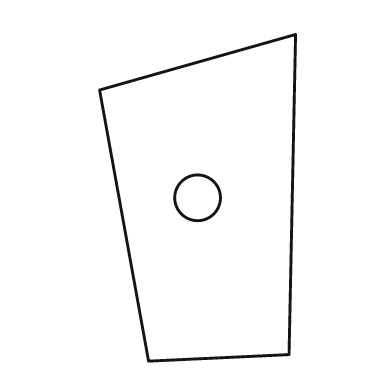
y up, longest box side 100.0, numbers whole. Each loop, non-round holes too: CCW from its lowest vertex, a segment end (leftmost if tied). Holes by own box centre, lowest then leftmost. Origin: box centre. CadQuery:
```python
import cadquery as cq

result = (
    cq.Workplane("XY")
    .moveTo(-15.0, -50.0)
    .lineTo(28.0, -48.0)
    .lineTo(30.0, 50.0)
    .lineTo(-30.0, 33.0)
    .close()
    .moveTo(0.0, 0.0)
    .circle(7.0)
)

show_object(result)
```